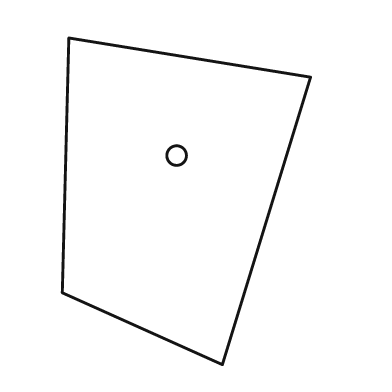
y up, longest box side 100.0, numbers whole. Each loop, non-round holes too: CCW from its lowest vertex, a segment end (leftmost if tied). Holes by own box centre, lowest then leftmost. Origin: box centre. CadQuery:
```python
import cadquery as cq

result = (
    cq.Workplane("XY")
    .moveTo(11.0, -50.0)
    .lineTo(38.0, 38.0)
    .lineTo(-36.0, 50.0)
    .lineTo(-38.0, -28.0)
    .close()
    .moveTo(-3.0, 14.0)
    .circle(3.0)
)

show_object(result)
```